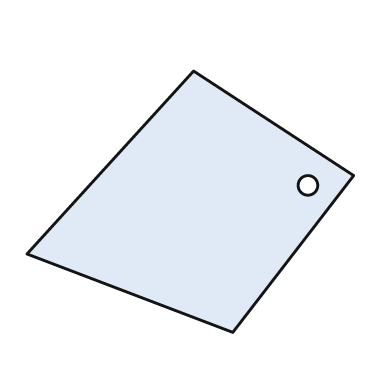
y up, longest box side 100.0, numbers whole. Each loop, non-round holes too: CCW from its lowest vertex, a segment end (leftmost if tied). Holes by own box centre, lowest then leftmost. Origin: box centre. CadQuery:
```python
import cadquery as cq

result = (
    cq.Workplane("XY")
    .moveTo(13.0, -40.0)
    .lineTo(50.0, 8.0)
    .lineTo(1.0, 40.0)
    .lineTo(-50.0, -16.0)
    .close()
    .moveTo(36.0, 5.0)
    .circle(3.0)
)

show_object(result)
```